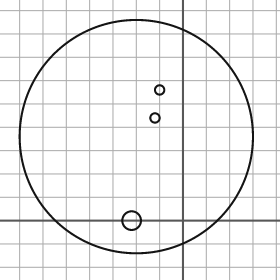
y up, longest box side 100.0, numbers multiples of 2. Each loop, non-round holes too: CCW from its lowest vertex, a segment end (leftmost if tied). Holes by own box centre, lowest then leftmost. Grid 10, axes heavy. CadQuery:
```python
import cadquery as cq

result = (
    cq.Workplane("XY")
    .moveTo(-20.0, 36.0)
    .circle(50.0)
    .moveTo(-22.0, 0.0)
    .circle(4.0)
    .moveTo(-12.0, 44.0)
    .circle(2.0)
    .moveTo(-10.0, 56.0)
    .circle(2.0)
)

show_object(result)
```